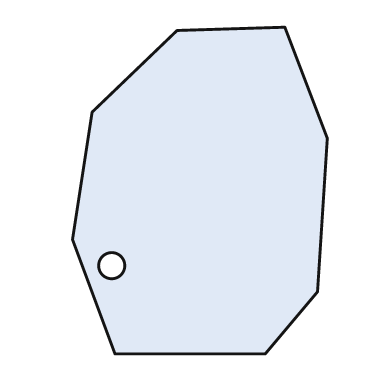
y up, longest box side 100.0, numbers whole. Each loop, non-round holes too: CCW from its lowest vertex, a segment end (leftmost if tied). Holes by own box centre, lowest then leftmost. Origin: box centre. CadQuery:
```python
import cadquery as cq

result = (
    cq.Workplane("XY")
    .moveTo(-26.0, -50.0)
    .lineTo(20.0, -50.0)
    .lineTo(36.0, -31.0)
    .lineTo(39.0, 16.0)
    .lineTo(26.0, 50.0)
    .lineTo(-7.0, 49.0)
    .lineTo(-33.0, 24.0)
    .lineTo(-39.0, -15.0)
    .close()
    .moveTo(-27.0, -23.0)
    .circle(4.0)
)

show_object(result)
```